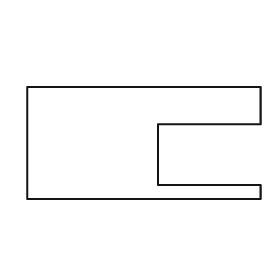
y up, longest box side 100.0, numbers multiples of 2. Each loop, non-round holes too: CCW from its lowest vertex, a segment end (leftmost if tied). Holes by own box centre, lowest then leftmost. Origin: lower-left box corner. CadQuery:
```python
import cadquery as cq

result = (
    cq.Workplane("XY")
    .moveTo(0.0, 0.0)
    .lineTo(100.0, 0.0)
    .lineTo(100.0, 6.0)
    .lineTo(56.0, 6.0)
    .lineTo(56.0, 32.0)
    .lineTo(100.0, 32.0)
    .lineTo(100.0, 48.0)
    .lineTo(0.0, 48.0)
    .close()
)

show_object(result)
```